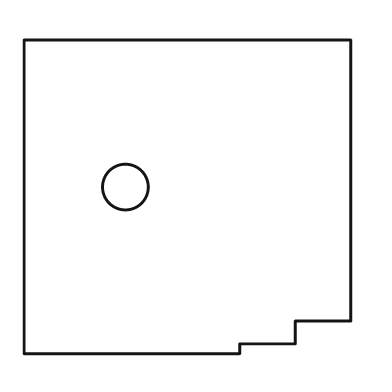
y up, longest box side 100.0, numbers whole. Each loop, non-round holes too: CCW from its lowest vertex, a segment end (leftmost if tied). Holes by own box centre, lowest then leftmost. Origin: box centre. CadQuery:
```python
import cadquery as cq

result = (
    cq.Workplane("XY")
    .moveTo(-50.0, -48.0)
    .lineTo(16.0, -48.0)
    .lineTo(16.0, -45.0)
    .lineTo(33.0, -45.0)
    .lineTo(33.0, -38.0)
    .lineTo(50.0, -38.0)
    .lineTo(50.0, 48.0)
    .lineTo(-50.0, 48.0)
    .close()
    .moveTo(-19.0, 3.0)
    .circle(7.0)
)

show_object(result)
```